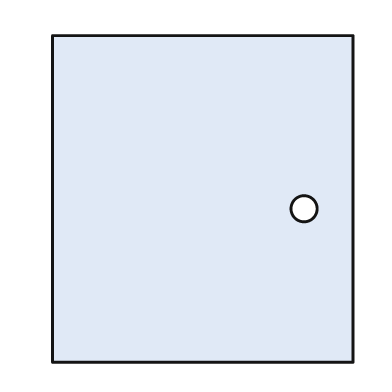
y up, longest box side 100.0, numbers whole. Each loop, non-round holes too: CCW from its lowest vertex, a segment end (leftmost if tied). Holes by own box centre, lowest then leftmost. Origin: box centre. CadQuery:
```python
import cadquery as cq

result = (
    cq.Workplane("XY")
    .moveTo(-46.0, -50.0)
    .lineTo(46.0, -50.0)
    .lineTo(46.0, 50.0)
    .lineTo(-46.0, 50.0)
    .close()
    .moveTo(31.0, -3.0)
    .circle(4.0)
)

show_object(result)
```